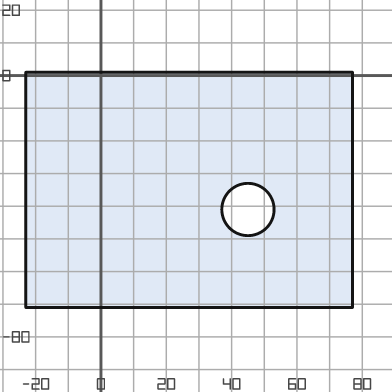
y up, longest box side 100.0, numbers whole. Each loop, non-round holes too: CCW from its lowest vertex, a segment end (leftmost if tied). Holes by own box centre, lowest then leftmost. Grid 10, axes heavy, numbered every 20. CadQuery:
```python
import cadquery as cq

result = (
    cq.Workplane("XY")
    .moveTo(-23.0, -71.0)
    .lineTo(77.0, -71.0)
    .lineTo(77.0, 1.0)
    .lineTo(-23.0, 1.0)
    .close()
    .moveTo(45.0, -41.0)
    .circle(8.0)
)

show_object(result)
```